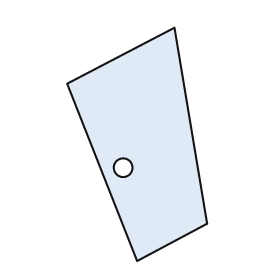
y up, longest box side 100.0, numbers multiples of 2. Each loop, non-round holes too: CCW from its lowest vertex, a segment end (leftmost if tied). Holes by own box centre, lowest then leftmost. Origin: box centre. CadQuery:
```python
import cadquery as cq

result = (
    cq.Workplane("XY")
    .moveTo(0.0, -50.0)
    .lineTo(30.0, -34.0)
    .lineTo(16.0, 50.0)
    .lineTo(-30.0, 26.0)
    .close()
    .moveTo(-6.0, -10.0)
    .circle(4.0)
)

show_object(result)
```